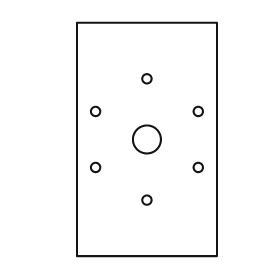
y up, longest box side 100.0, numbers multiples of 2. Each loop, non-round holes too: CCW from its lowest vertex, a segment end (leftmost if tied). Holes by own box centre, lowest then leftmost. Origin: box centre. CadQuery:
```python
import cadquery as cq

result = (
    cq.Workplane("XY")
    .moveTo(-30.0, -50.0)
    .lineTo(30.0, -50.0)
    .lineTo(30.0, 50.0)
    .lineTo(-30.0, 50.0)
    .close()
    .moveTo(0.0, -26.0)
    .circle(2.0)
    .moveTo(-22.0, -12.0)
    .circle(2.0)
    .moveTo(22.0, -12.0)
    .circle(2.0)
    .moveTo(0.0, 0.0)
    .circle(6.0)
    .moveTo(-22.0, 12.0)
    .circle(2.0)
    .moveTo(22.0, 12.0)
    .circle(2.0)
    .moveTo(0.0, 26.0)
    .circle(2.0)
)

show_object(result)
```